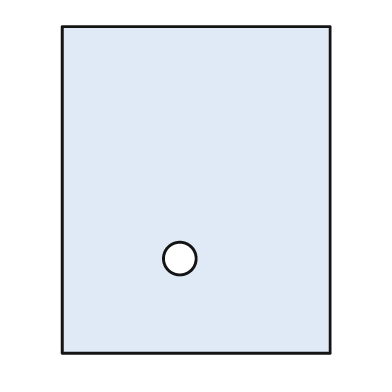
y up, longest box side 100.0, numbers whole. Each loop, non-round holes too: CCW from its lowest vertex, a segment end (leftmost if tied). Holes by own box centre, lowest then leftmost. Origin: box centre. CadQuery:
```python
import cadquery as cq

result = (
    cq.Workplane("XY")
    .moveTo(-41.0, -50.0)
    .lineTo(41.0, -50.0)
    .lineTo(41.0, 50.0)
    .lineTo(-41.0, 50.0)
    .close()
    .moveTo(-5.0, -21.0)
    .circle(5.0)
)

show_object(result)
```